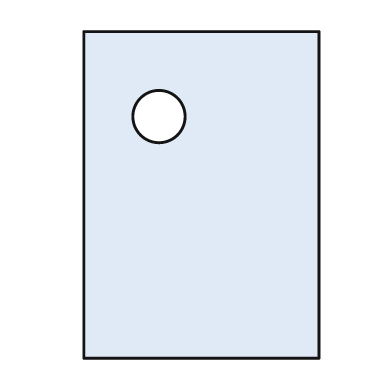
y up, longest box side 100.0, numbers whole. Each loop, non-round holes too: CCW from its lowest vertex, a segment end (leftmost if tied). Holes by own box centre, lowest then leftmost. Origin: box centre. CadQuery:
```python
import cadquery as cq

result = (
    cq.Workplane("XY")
    .moveTo(-36.0, -50.0)
    .lineTo(36.0, -50.0)
    .lineTo(36.0, 50.0)
    .lineTo(-36.0, 50.0)
    .close()
    .moveTo(-13.0, 24.0)
    .circle(8.0)
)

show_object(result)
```